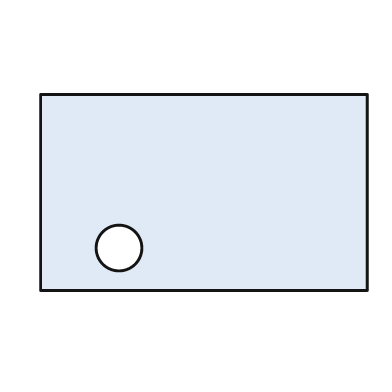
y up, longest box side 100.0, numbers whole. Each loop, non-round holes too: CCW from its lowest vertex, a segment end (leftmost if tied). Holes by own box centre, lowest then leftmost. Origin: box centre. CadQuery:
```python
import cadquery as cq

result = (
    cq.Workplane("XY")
    .moveTo(-50.0, -30.0)
    .lineTo(50.0, -30.0)
    .lineTo(50.0, 30.0)
    .lineTo(-50.0, 30.0)
    .close()
    .moveTo(-26.0, -17.0)
    .circle(7.0)
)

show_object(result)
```